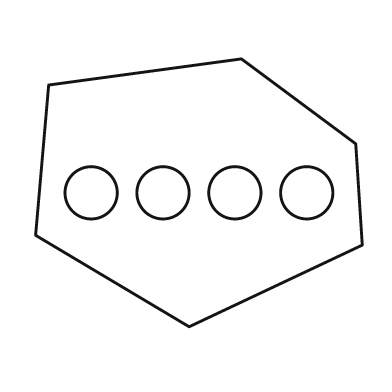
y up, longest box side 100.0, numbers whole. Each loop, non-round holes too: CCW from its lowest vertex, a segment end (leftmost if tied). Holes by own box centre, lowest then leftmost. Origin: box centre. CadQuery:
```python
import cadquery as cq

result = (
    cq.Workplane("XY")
    .moveTo(-3.0, -41.0)
    .lineTo(50.0, -16.0)
    .lineTo(48.0, 15.0)
    .lineTo(13.0, 41.0)
    .lineTo(-46.0, 33.0)
    .lineTo(-50.0, -13.0)
    .close()
    .moveTo(-33.0, 0.0)
    .circle(8.0)
    .moveTo(-11.0, 0.0)
    .circle(8.0)
    .moveTo(11.0, 0.0)
    .circle(8.0)
    .moveTo(33.0, 0.0)
    .circle(8.0)
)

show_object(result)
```